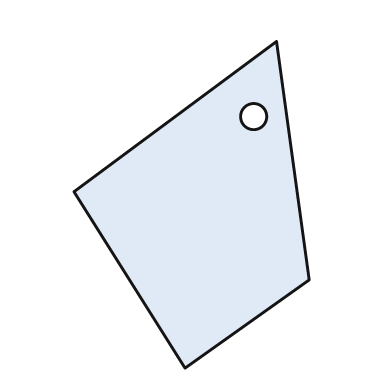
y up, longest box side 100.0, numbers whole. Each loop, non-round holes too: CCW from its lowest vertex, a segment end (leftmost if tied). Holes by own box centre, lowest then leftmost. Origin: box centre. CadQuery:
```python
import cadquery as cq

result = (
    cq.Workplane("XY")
    .moveTo(-2.0, -50.0)
    .lineTo(36.0, -23.0)
    .lineTo(26.0, 50.0)
    .lineTo(-36.0, 4.0)
    .close()
    .moveTo(19.0, 27.0)
    .circle(4.0)
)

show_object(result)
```